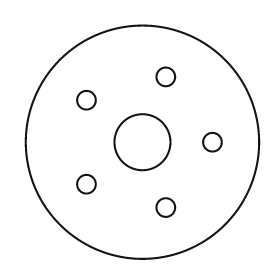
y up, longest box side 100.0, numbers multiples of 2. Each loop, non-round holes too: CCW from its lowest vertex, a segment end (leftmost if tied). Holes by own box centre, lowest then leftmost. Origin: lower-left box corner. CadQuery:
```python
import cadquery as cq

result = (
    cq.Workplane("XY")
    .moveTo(50.0, 50.0)
    .circle(50.0)
    .moveTo(60.0, 22.0)
    .circle(4.0)
    .moveTo(26.0, 32.0)
    .circle(4.0)
    .moveTo(50.0, 50.0)
    .circle(12.0)
    .moveTo(80.0, 50.0)
    .circle(4.0)
    .moveTo(26.0, 68.0)
    .circle(4.0)
    .moveTo(60.0, 78.0)
    .circle(4.0)
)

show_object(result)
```